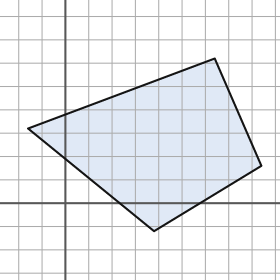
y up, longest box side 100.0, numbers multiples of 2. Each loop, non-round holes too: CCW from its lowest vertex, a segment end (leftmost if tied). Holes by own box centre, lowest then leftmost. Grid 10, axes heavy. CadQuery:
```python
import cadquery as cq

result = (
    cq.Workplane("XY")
    .moveTo(38.0, -12.0)
    .lineTo(84.0, 16.0)
    .lineTo(64.0, 62.0)
    .lineTo(-16.0, 32.0)
    .close()
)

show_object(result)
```